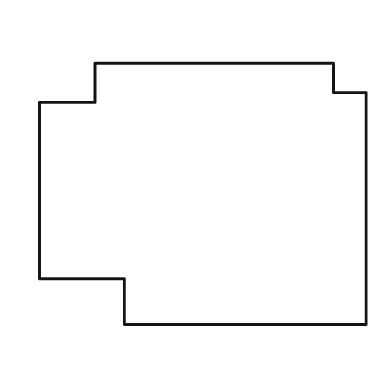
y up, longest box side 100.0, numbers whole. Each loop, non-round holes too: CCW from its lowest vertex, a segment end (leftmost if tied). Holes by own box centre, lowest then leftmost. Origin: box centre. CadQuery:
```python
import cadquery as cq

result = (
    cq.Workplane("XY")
    .moveTo(-24.0, -40.0)
    .lineTo(50.0, -40.0)
    .lineTo(50.0, 31.0)
    .lineTo(40.0, 31.0)
    .lineTo(40.0, 40.0)
    .lineTo(-33.0, 40.0)
    .lineTo(-33.0, 28.0)
    .lineTo(-50.0, 28.0)
    .lineTo(-50.0, -26.0)
    .lineTo(-24.0, -26.0)
    .close()
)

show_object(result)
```